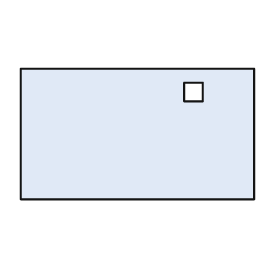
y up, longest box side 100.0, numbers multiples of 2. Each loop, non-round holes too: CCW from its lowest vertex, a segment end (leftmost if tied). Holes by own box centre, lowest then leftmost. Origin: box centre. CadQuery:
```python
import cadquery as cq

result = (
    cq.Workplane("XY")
    .moveTo(-50.0, -28.0)
    .lineTo(50.0, -28.0)
    .lineTo(50.0, 28.0)
    .lineTo(-50.0, 28.0)
    .close()
    .moveTo(20.0, 14.0)
    .lineTo(28.0, 14.0)
    .lineTo(28.0, 22.0)
    .lineTo(20.0, 22.0)
    .close()
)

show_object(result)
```